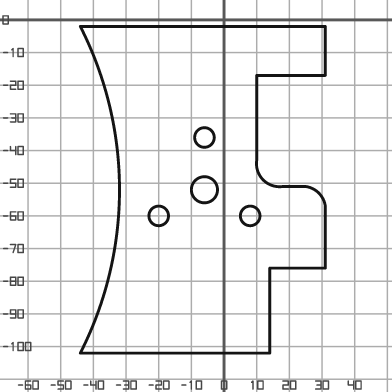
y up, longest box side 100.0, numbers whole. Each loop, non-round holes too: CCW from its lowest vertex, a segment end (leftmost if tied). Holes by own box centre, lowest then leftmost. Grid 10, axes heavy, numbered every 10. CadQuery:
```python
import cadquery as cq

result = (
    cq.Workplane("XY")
    .moveTo(-44.0, -102.0)
    .lineTo(14.0, -102.0)
    .lineTo(14.0, -76.0)
    .lineTo(31.0, -76.0)
    .lineTo(31.0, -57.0)
    .threePointArc((29.0, -53.0), (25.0, -51.0))
    .lineTo(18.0, -51.0)
    .threePointArc((12.0, -49.0), (10.0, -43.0))
    .lineTo(10.0, -17.0)
    .lineTo(31.0, -17.0)
    .lineTo(31.0, -2.0)
    .lineTo(-44.0, -2.0)
    .threePointArc((-32.0, -52.0), (-44.0, -102.0))
    .close()
    .moveTo(-20.0, -60.0)
    .circle(3.0)
    .moveTo(8.0, -60.0)
    .circle(3.0)
    .moveTo(-6.0, -52.0)
    .circle(4.0)
    .moveTo(-6.0, -36.0)
    .circle(3.0)
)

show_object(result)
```